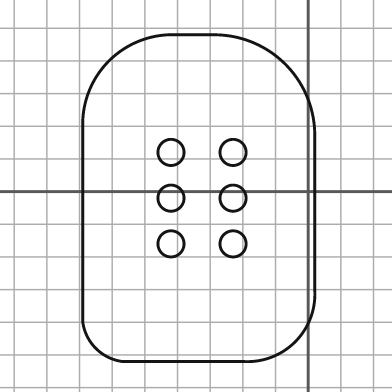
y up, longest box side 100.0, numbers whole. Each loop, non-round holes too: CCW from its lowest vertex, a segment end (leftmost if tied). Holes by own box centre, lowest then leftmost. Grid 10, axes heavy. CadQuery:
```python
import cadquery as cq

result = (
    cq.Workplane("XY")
    .moveTo(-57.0, -52.0)
    .lineTo(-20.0, -52.0)
    .threePointArc((-4.0, -46.0), (2.0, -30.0))
    .lineTo(2.0, 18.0)
    .threePointArc((-7.0, 39.0), (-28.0, 48.0))
    .lineTo(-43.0, 48.0)
    .threePointArc((-61.0, 40.0), (-69.0, 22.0))
    .lineTo(-69.0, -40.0)
    .threePointArc((-65.0, -48.0), (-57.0, -52.0))
    .close()
    .moveTo(-42.0, -16.0)
    .circle(4.0)
    .moveTo(-23.0, -16.0)
    .circle(4.0)
    .moveTo(-42.0, -2.0)
    .circle(4.0)
    .moveTo(-23.0, -2.0)
    .circle(4.0)
    .moveTo(-42.0, 12.0)
    .circle(4.0)
    .moveTo(-23.0, 12.0)
    .circle(4.0)
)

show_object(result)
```